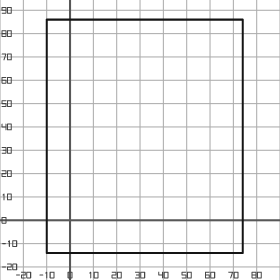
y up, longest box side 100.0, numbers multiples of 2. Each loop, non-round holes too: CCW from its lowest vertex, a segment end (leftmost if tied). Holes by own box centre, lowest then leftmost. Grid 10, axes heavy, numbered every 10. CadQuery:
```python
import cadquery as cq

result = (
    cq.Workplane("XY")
    .moveTo(-10.0, -14.0)
    .lineTo(74.0, -14.0)
    .lineTo(74.0, 86.0)
    .lineTo(-10.0, 86.0)
    .close()
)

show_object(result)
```